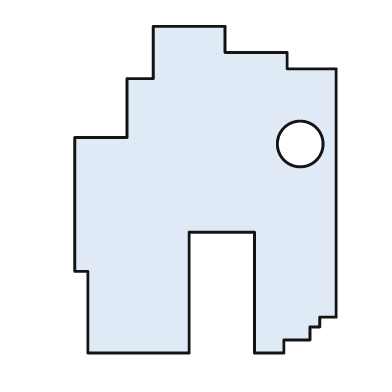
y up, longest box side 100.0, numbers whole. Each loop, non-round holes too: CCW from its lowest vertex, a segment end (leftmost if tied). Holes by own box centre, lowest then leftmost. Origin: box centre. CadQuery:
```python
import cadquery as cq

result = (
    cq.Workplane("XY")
    .moveTo(-36.0, -50.0)
    .lineTo(-5.0, -50.0)
    .lineTo(-5.0, -13.0)
    .lineTo(15.0, -13.0)
    .lineTo(15.0, -50.0)
    .lineTo(24.0, -50.0)
    .lineTo(24.0, -46.0)
    .lineTo(32.0, -46.0)
    .lineTo(32.0, -42.0)
    .lineTo(35.0, -42.0)
    .lineTo(35.0, -39.0)
    .lineTo(40.0, -39.0)
    .lineTo(40.0, 37.0)
    .lineTo(25.0, 37.0)
    .lineTo(25.0, 42.0)
    .lineTo(6.0, 42.0)
    .lineTo(6.0, 50.0)
    .lineTo(-16.0, 50.0)
    .lineTo(-16.0, 34.0)
    .lineTo(-24.0, 34.0)
    .lineTo(-24.0, 16.0)
    .lineTo(-40.0, 16.0)
    .lineTo(-40.0, -25.0)
    .lineTo(-36.0, -25.0)
    .close()
    .moveTo(29.0, 14.0)
    .circle(7.0)
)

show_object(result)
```